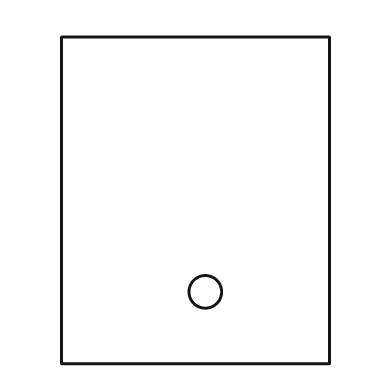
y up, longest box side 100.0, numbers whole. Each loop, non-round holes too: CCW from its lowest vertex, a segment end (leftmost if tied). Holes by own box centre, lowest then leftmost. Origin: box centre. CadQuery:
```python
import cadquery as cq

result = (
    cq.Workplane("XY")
    .moveTo(-41.0, -50.0)
    .lineTo(41.0, -50.0)
    .lineTo(41.0, 50.0)
    .lineTo(-41.0, 50.0)
    .close()
    .moveTo(3.0, -28.0)
    .circle(5.0)
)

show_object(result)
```